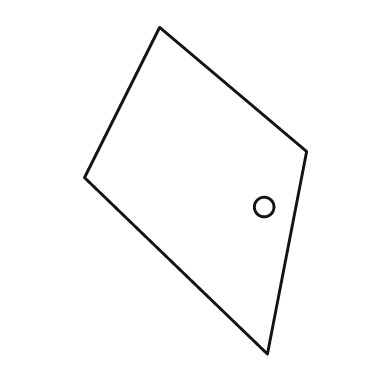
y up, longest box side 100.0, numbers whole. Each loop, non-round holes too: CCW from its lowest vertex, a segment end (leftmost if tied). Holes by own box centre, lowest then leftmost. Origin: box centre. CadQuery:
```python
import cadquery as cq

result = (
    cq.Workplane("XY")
    .moveTo(22.0, -50.0)
    .lineTo(34.0, 12.0)
    .lineTo(-11.0, 50.0)
    .lineTo(-34.0, 4.0)
    .close()
    .moveTo(21.0, -5.0)
    .circle(3.0)
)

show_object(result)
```